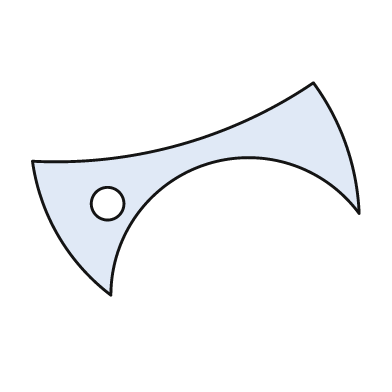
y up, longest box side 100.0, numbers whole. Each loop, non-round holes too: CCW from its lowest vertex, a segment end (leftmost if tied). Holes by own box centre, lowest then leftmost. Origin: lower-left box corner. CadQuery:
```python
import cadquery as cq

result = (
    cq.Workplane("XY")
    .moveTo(24.0, 0.0)
    .threePointArc((53.0, 40.0), (100.0, 25.0))
    .threePointArc((96.0, 46.0), (86.0, 65.0))
    .threePointArc((45.0, 46.0), (0.0, 41.0))
    .threePointArc((8.0, 18.0), (24.0, 0.0))
    .close()
    .moveTo(23.0, 28.0)
    .circle(5.0)
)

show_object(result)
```